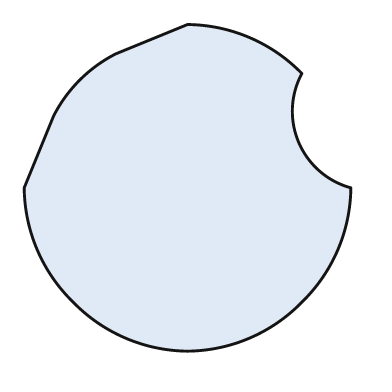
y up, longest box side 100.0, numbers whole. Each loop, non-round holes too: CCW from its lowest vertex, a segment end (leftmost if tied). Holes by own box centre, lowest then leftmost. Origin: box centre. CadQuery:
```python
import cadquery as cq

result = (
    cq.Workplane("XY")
    .moveTo(0.0, -50.0)
    .threePointArc((19.0, -46.0), (35.0, -35.0))
    .threePointArc((46.0, -19.0), (50.0, 0.0))
    .threePointArc((34.0, 14.0), (35.0, 35.0))
    .threePointArc((19.0, 46.0), (0.0, 50.0))
    .lineTo(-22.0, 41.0)
    .threePointArc((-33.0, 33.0), (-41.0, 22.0))
    .lineTo(-50.0, 0.0)
    .threePointArc((-46.0, -19.0), (-35.0, -35.0))
    .threePointArc((-19.0, -46.0), (0.0, -50.0))
    .close()
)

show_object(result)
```